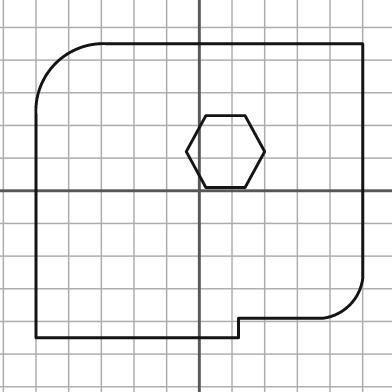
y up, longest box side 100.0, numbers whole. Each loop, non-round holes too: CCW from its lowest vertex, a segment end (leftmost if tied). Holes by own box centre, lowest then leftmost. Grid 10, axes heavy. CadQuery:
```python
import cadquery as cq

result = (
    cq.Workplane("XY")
    .moveTo(-50.0, -45.0)
    .lineTo(12.0, -45.0)
    .lineTo(12.0, -39.0)
    .lineTo(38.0, -39.0)
    .threePointArc((46.0, -35.0), (50.0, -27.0))
    .lineTo(50.0, 45.0)
    .lineTo(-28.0, 45.0)
    .threePointArc((-44.0, 39.0), (-50.0, 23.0))
    .close()
    .moveTo(2.0, 1.0)
    .lineTo(14.0, 1.0)
    .lineTo(20.0, 12.0)
    .lineTo(14.0, 23.0)
    .lineTo(2.0, 23.0)
    .lineTo(-4.0, 12.0)
    .close()
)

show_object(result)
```